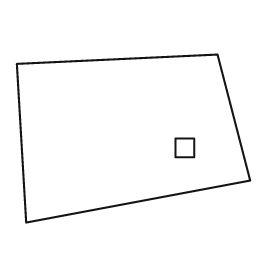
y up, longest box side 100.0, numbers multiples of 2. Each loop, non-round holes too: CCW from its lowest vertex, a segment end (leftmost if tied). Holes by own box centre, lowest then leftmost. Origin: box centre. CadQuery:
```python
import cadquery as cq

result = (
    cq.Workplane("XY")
    .moveTo(-46.0, -36.0)
    .lineTo(50.0, -18.0)
    .lineTo(36.0, 36.0)
    .lineTo(-50.0, 32.0)
    .close()
    .moveTo(18.0, -8.0)
    .lineTo(26.0, -8.0)
    .lineTo(26.0, 0.0)
    .lineTo(18.0, 0.0)
    .close()
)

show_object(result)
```